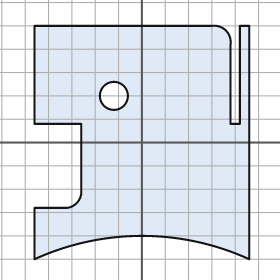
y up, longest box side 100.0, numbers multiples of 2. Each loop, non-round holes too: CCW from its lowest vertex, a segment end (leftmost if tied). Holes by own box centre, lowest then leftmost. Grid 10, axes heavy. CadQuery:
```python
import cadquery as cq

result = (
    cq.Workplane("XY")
    .moveTo(-46.0, -50.0)
    .threePointArc((0.0, -40.0), (46.0, -50.0))
    .lineTo(46.0, 50.0)
    .lineTo(42.0, 50.0)
    .lineTo(42.0, 8.0)
    .lineTo(38.0, 8.0)
    .lineTo(38.0, 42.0)
    .threePointArc((36.0, 48.0), (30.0, 50.0))
    .lineTo(-46.0, 50.0)
    .lineTo(-46.0, 8.0)
    .lineTo(-26.0, 8.0)
    .lineTo(-26.0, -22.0)
    .threePointArc((-28.0, -26.0), (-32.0, -28.0))
    .lineTo(-46.0, -28.0)
    .close()
    .moveTo(-12.0, 20.0)
    .circle(6.0)
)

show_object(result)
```